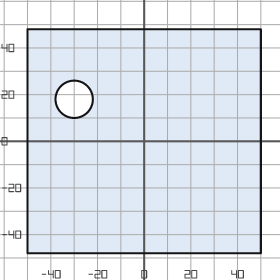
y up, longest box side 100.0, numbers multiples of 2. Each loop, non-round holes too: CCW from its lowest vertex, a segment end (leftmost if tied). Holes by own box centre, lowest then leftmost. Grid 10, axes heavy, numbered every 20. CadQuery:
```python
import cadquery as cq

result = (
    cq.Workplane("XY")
    .moveTo(-50.0, -48.0)
    .lineTo(50.0, -48.0)
    .lineTo(50.0, 48.0)
    .lineTo(-50.0, 48.0)
    .close()
    .moveTo(-30.0, 18.0)
    .circle(8.0)
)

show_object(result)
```